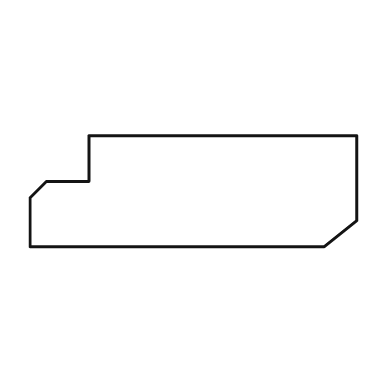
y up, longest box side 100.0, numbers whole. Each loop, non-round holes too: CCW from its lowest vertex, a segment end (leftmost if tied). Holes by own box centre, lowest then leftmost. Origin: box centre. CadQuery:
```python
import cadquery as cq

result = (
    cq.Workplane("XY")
    .moveTo(-50.0, -17.0)
    .lineTo(40.0, -17.0)
    .lineTo(50.0, -9.0)
    .lineTo(50.0, 17.0)
    .lineTo(-32.0, 17.0)
    .lineTo(-32.0, 3.0)
    .lineTo(-45.0, 3.0)
    .lineTo(-50.0, -2.0)
    .close()
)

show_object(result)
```